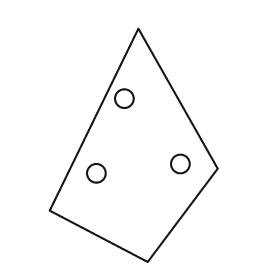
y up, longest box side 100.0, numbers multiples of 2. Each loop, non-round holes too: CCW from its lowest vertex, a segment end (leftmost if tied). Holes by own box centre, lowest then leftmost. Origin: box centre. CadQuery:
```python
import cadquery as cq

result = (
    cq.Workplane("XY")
    .moveTo(6.0, -50.0)
    .lineTo(36.0, -10.0)
    .lineTo(2.0, 50.0)
    .lineTo(-36.0, -28.0)
    .close()
    .moveTo(-16.0, -12.0)
    .circle(4.0)
    .moveTo(20.0, -8.0)
    .circle(4.0)
    .moveTo(-4.0, 20.0)
    .circle(4.0)
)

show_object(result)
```